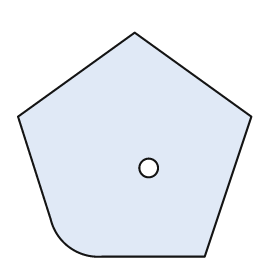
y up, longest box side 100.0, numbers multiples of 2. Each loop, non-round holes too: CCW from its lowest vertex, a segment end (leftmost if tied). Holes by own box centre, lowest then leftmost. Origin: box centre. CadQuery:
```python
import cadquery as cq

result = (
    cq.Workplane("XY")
    .moveTo(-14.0, -48.0)
    .lineTo(30.0, -48.0)
    .lineTo(50.0, 12.0)
    .lineTo(0.0, 48.0)
    .lineTo(-50.0, 12.0)
    .lineTo(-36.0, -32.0)
    .threePointArc((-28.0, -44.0), (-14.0, -48.0))
    .close()
    .moveTo(6.0, -10.0)
    .circle(4.0)
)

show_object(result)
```